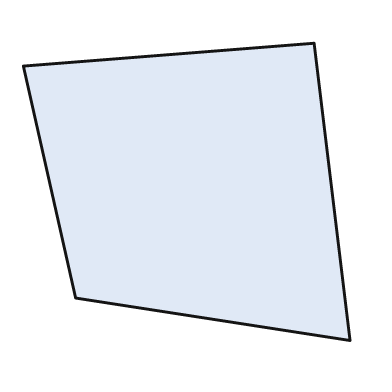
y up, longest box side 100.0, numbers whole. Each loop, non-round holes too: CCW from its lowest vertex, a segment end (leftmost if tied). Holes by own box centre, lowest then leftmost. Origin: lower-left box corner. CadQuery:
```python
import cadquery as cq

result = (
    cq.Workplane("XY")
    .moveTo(100.0, 0.0)
    .lineTo(89.0, 91.0)
    .lineTo(0.0, 84.0)
    .lineTo(16.0, 13.0)
    .close()
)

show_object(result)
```